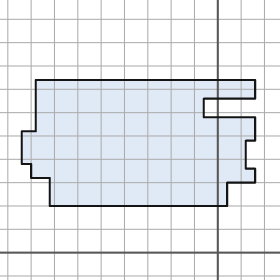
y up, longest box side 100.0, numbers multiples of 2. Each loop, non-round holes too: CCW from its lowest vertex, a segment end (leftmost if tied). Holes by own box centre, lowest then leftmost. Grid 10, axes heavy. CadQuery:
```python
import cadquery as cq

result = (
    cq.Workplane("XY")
    .moveTo(-72.0, 20.0)
    .lineTo(4.0, 20.0)
    .lineTo(4.0, 30.0)
    .lineTo(16.0, 30.0)
    .lineTo(16.0, 36.0)
    .lineTo(12.0, 36.0)
    .lineTo(12.0, 48.0)
    .lineTo(16.0, 48.0)
    .lineTo(16.0, 58.0)
    .lineTo(-6.0, 58.0)
    .lineTo(-6.0, 66.0)
    .lineTo(16.0, 66.0)
    .lineTo(16.0, 74.0)
    .lineTo(-78.0, 74.0)
    .lineTo(-78.0, 52.0)
    .lineTo(-84.0, 52.0)
    .lineTo(-84.0, 38.0)
    .lineTo(-80.0, 38.0)
    .lineTo(-80.0, 32.0)
    .lineTo(-72.0, 32.0)
    .close()
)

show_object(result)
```